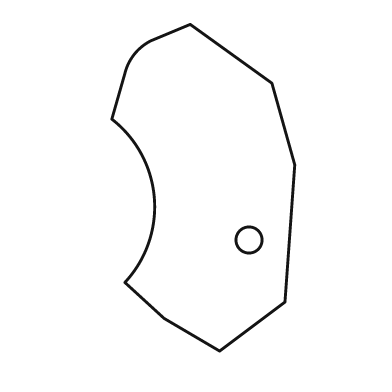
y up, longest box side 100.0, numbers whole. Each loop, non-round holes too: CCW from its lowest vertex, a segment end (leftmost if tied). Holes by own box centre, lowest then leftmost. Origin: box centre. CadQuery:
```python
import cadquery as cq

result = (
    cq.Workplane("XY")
    .moveTo(5.0, -50.0)
    .lineTo(25.0, -35.0)
    .lineTo(28.0, 7.0)
    .lineTo(21.0, 32.0)
    .lineTo(-4.0, 50.0)
    .lineTo(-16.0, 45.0)
    .threePointArc((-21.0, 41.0), (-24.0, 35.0))
    .lineTo(-28.0, 21.0)
    .threePointArc((-15.0, -3.0), (-24.0, -29.0))
    .lineTo(-12.0, -40.0)
    .close()
    .moveTo(14.0, -16.0)
    .circle(4.0)
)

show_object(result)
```